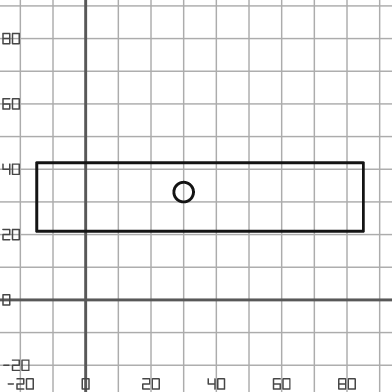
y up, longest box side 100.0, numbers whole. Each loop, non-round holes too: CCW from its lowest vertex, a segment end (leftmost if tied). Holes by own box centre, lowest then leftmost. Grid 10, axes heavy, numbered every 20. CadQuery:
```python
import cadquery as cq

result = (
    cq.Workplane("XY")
    .moveTo(-15.0, 21.0)
    .lineTo(85.0, 21.0)
    .lineTo(85.0, 42.0)
    .lineTo(-15.0, 42.0)
    .close()
    .moveTo(30.0, 33.0)
    .circle(3.0)
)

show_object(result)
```